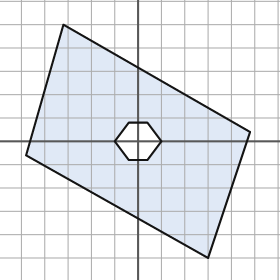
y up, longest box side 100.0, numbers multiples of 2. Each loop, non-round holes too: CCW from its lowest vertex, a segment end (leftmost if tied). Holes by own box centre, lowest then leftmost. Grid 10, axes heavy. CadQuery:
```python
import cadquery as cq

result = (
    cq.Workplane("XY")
    .moveTo(30.0, -50.0)
    .lineTo(48.0, 4.0)
    .lineTo(-32.0, 50.0)
    .lineTo(-48.0, -6.0)
    .close()
    .moveTo(-4.0, -8.0)
    .lineTo(4.0, -8.0)
    .lineTo(10.0, 0.0)
    .lineTo(4.0, 8.0)
    .lineTo(-4.0, 8.0)
    .lineTo(-10.0, 0.0)
    .close()
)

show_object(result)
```